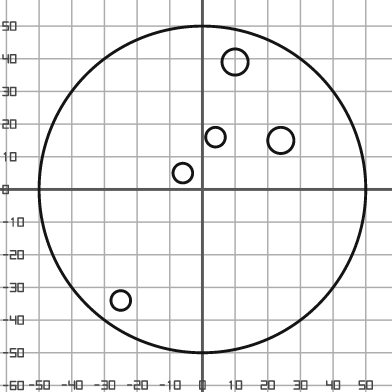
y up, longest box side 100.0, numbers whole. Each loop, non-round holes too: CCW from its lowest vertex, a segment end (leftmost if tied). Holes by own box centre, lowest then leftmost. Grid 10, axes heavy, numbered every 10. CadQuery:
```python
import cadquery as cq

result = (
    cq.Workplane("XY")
    .moveTo(0.0, 0.0)
    .circle(50.0)
    .moveTo(-25.0, -34.0)
    .circle(3.0)
    .moveTo(-6.0, 5.0)
    .circle(3.0)
    .moveTo(24.0, 15.0)
    .circle(4.0)
    .moveTo(4.0, 16.0)
    .circle(3.0)
    .moveTo(10.0, 39.0)
    .circle(4.0)
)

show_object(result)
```